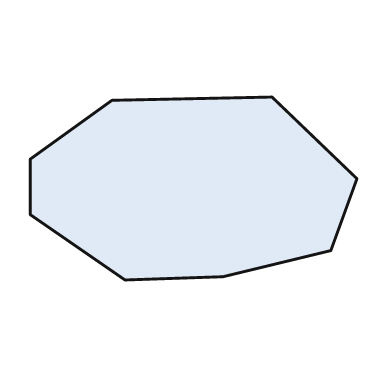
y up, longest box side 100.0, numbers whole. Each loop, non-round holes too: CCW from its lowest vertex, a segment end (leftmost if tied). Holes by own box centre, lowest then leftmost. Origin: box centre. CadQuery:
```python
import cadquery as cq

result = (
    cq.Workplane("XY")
    .moveTo(-21.0, -28.0)
    .lineTo(9.0, -27.0)
    .lineTo(42.0, -19.0)
    .lineTo(50.0, 3.0)
    .lineTo(24.0, 28.0)
    .lineTo(-25.0, 27.0)
    .lineTo(-50.0, 9.0)
    .lineTo(-50.0, -8.0)
    .close()
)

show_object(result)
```